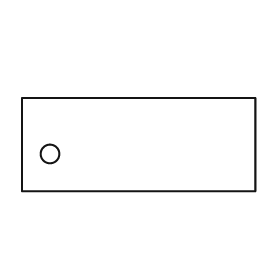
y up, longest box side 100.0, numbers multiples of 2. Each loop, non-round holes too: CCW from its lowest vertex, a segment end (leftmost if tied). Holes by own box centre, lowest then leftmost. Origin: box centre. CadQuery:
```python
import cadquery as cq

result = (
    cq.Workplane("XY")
    .moveTo(-50.0, -20.0)
    .lineTo(50.0, -20.0)
    .lineTo(50.0, 20.0)
    .lineTo(-50.0, 20.0)
    .close()
    .moveTo(-38.0, -4.0)
    .circle(4.0)
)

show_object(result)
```